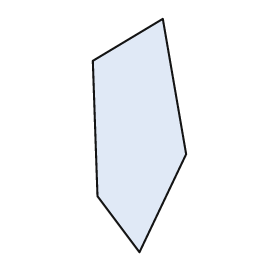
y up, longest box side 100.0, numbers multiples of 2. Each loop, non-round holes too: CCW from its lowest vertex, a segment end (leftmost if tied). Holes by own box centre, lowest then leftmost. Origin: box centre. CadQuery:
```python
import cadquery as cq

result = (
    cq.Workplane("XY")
    .moveTo(0.0, -50.0)
    .lineTo(20.0, -8.0)
    .lineTo(10.0, 50.0)
    .lineTo(-20.0, 32.0)
    .lineTo(-18.0, -26.0)
    .close()
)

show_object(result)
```